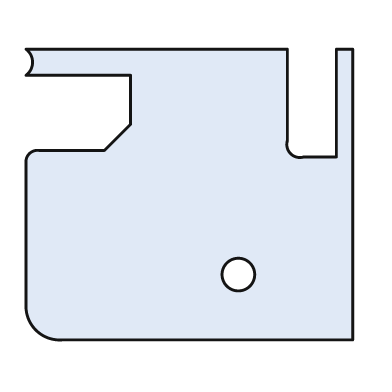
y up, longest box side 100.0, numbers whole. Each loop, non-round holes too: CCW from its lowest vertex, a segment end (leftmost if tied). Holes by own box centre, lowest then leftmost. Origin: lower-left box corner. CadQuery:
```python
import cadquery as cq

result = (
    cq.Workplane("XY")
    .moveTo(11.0, 0.0)
    .lineTo(100.0, 0.0)
    .lineTo(100.0, 89.0)
    .lineTo(95.0, 89.0)
    .lineTo(95.0, 56.0)
    .lineTo(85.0, 56.0)
    .threePointArc((81.0, 57.0), (80.0, 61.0))
    .lineTo(80.0, 89.0)
    .lineTo(0.0, 89.0)
    .threePointArc((2.0, 85.0), (0.0, 81.0))
    .lineTo(32.0, 81.0)
    .lineTo(32.0, 66.0)
    .lineTo(24.0, 58.0)
    .lineTo(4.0, 58.0)
    .threePointArc((1.0, 57.0), (0.0, 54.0))
    .lineTo(0.0, 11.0)
    .threePointArc((3.0, 3.0), (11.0, 0.0))
    .close()
    .moveTo(65.0, 20.0)
    .circle(5.0)
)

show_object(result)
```